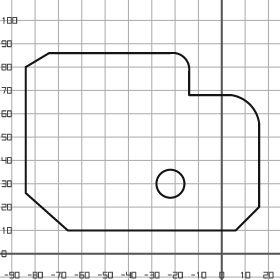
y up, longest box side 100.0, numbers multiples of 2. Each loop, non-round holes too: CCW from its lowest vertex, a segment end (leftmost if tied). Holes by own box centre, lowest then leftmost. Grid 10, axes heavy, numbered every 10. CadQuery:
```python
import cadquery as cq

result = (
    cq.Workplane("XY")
    .moveTo(-66.0, 10.0)
    .lineTo(6.0, 10.0)
    .lineTo(16.0, 20.0)
    .lineTo(16.0, 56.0)
    .threePointArc((12.0, 64.0), (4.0, 68.0))
    .lineTo(-14.0, 68.0)
    .lineTo(-14.0, 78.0)
    .threePointArc((-16.0, 84.0), (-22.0, 86.0))
    .lineTo(-74.0, 86.0)
    .lineTo(-84.0, 80.0)
    .lineTo(-84.0, 26.0)
    .close()
    .moveTo(-22.0, 30.0)
    .circle(6.0)
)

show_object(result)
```